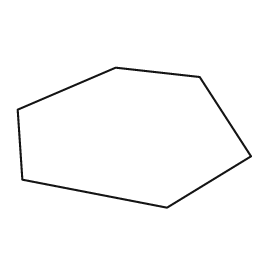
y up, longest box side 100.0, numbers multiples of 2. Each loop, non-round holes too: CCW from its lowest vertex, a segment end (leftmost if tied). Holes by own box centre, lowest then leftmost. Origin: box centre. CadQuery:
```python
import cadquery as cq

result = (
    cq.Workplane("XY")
    .moveTo(14.0, -30.0)
    .lineTo(50.0, -8.0)
    .lineTo(28.0, 26.0)
    .lineTo(-8.0, 30.0)
    .lineTo(-50.0, 12.0)
    .lineTo(-48.0, -18.0)
    .close()
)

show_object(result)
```